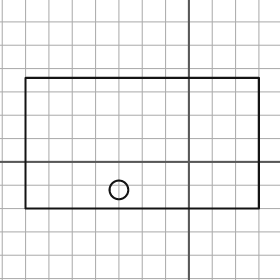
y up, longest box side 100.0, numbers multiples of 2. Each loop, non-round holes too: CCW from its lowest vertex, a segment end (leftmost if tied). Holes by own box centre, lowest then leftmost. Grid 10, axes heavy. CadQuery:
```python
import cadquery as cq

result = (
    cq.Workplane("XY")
    .moveTo(-70.0, -20.0)
    .lineTo(30.0, -20.0)
    .lineTo(30.0, 36.0)
    .lineTo(-70.0, 36.0)
    .close()
    .moveTo(-30.0, -12.0)
    .circle(4.0)
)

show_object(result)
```